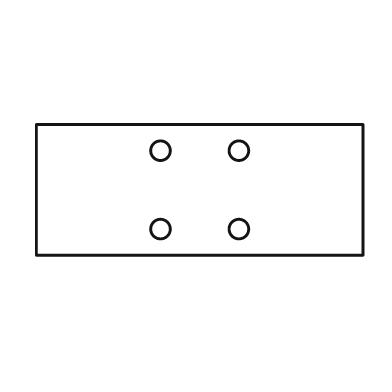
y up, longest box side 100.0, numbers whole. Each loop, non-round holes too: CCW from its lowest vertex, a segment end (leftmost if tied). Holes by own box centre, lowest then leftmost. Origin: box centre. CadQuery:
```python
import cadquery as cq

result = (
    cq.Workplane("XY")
    .moveTo(-50.0, -20.0)
    .lineTo(50.0, -20.0)
    .lineTo(50.0, 20.0)
    .lineTo(-50.0, 20.0)
    .close()
    .moveTo(-12.0, -12.0)
    .circle(3.0)
    .moveTo(12.0, -12.0)
    .circle(3.0)
    .moveTo(-12.0, 12.0)
    .circle(3.0)
    .moveTo(12.0, 12.0)
    .circle(3.0)
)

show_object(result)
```